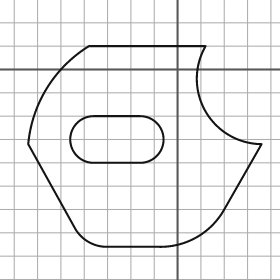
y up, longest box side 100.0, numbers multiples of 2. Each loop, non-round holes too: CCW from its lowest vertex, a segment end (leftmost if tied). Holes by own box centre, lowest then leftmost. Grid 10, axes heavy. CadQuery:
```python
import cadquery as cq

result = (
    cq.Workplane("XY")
    .moveTo(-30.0, -76.0)
    .lineTo(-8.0, -76.0)
    .threePointArc((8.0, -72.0), (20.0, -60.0))
    .lineTo(36.0, -32.0)
    .threePointArc((12.0, -18.0), (12.0, 10.0))
    .lineTo(-38.0, 10.0)
    .threePointArc((-56.0, -8.0), (-64.0, -32.0))
    .lineTo(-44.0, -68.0)
    .threePointArc((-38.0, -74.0), (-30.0, -76.0))
    .close()
    .moveTo(-36.0, -40.0)
    .lineTo(-16.0, -40.0)
    .threePointArc((-6.0, -30.0), (-16.0, -20.0))
    .lineTo(-36.0, -20.0)
    .threePointArc((-46.0, -30.0), (-36.0, -40.0))
    .close()
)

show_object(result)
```